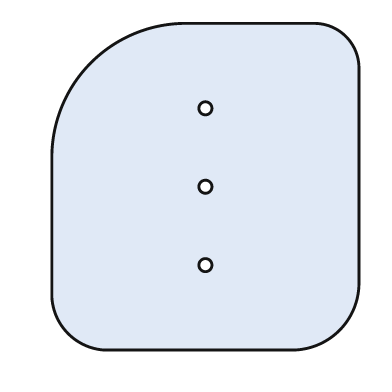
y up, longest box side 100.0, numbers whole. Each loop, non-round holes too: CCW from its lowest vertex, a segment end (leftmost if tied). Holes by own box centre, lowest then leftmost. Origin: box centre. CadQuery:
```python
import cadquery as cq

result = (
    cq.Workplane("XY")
    .moveTo(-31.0, -50.0)
    .lineTo(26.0, -50.0)
    .threePointArc((41.0, -44.0), (47.0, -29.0))
    .lineTo(47.0, 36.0)
    .threePointArc((43.0, 46.0), (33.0, 50.0))
    .lineTo(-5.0, 50.0)
    .threePointArc((-35.0, 38.0), (-47.0, 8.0))
    .lineTo(-47.0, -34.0)
    .threePointArc((-42.0, -45.0), (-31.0, -50.0))
    .close()
    .moveTo(0.0, -24.0)
    .circle(2.0)
    .moveTo(0.0, 0.0)
    .circle(2.0)
    .moveTo(0.0, 24.0)
    .circle(2.0)
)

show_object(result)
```